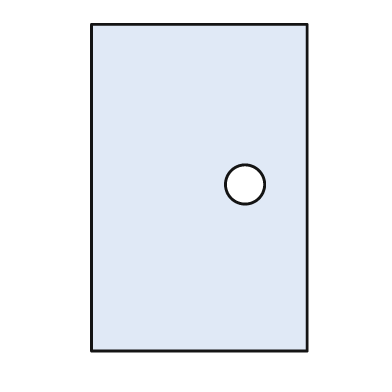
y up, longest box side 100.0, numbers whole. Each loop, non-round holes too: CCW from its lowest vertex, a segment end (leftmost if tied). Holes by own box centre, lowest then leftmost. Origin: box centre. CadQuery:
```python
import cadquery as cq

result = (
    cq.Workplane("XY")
    .moveTo(-33.0, -50.0)
    .lineTo(33.0, -50.0)
    .lineTo(33.0, 50.0)
    .lineTo(-33.0, 50.0)
    .close()
    .moveTo(14.0, 1.0)
    .circle(6.0)
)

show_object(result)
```